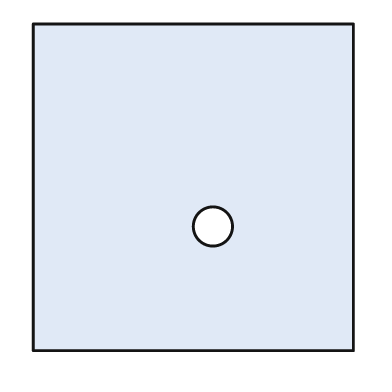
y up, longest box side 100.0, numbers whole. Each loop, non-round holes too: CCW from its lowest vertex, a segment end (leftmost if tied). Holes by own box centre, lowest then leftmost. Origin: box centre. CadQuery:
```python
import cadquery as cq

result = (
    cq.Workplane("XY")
    .moveTo(-49.0, -50.0)
    .lineTo(49.0, -50.0)
    .lineTo(49.0, 50.0)
    .lineTo(-49.0, 50.0)
    .close()
    .moveTo(6.0, -12.0)
    .circle(6.0)
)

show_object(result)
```